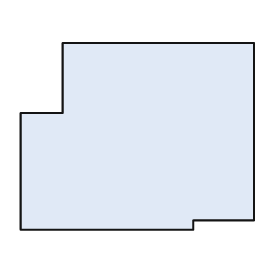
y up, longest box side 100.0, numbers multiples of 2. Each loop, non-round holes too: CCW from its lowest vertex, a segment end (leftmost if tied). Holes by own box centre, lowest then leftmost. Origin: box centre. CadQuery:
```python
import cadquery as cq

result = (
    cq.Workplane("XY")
    .moveTo(-50.0, -40.0)
    .lineTo(24.0, -40.0)
    .lineTo(24.0, -36.0)
    .lineTo(50.0, -36.0)
    .lineTo(50.0, 40.0)
    .lineTo(-32.0, 40.0)
    .lineTo(-32.0, 10.0)
    .lineTo(-50.0, 10.0)
    .close()
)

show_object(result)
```